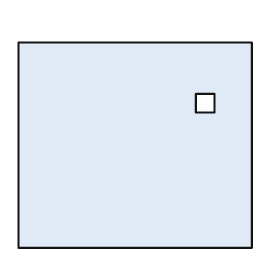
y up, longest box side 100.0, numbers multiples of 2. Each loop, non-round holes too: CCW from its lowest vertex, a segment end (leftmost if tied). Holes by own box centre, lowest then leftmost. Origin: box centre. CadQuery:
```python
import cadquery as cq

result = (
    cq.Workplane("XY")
    .moveTo(-50.0, -44.0)
    .lineTo(50.0, -44.0)
    .lineTo(50.0, 44.0)
    .lineTo(-50.0, 44.0)
    .close()
    .moveTo(26.0, 14.0)
    .lineTo(34.0, 14.0)
    .lineTo(34.0, 22.0)
    .lineTo(26.0, 22.0)
    .close()
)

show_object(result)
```